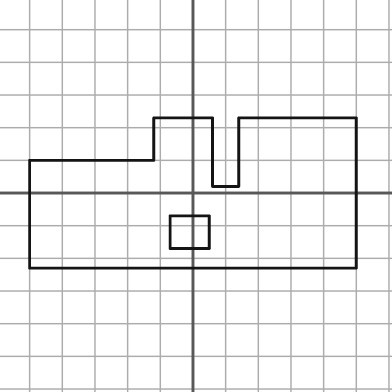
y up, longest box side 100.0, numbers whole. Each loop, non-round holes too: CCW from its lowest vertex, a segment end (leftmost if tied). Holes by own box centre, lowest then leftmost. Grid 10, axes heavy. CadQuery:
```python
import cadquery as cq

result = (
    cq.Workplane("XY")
    .moveTo(-50.0, -23.0)
    .lineTo(50.0, -23.0)
    .lineTo(50.0, 23.0)
    .lineTo(14.0, 23.0)
    .lineTo(14.0, 2.0)
    .lineTo(6.0, 2.0)
    .lineTo(6.0, 23.0)
    .lineTo(-12.0, 23.0)
    .lineTo(-12.0, 10.0)
    .lineTo(-50.0, 10.0)
    .close()
    .moveTo(-7.0, -17.0)
    .lineTo(5.0, -17.0)
    .lineTo(5.0, -7.0)
    .lineTo(-7.0, -7.0)
    .close()
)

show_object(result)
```